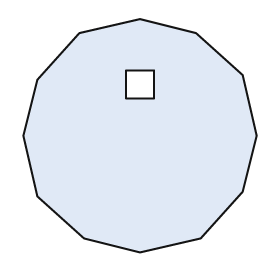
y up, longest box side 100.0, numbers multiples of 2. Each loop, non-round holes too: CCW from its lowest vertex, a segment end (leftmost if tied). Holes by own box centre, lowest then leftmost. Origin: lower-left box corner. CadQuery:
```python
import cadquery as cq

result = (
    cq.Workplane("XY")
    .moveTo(50.0, 0.0)
    .lineTo(76.0, 6.0)
    .lineTo(94.0, 26.0)
    .lineTo(100.0, 50.0)
    .lineTo(94.0, 76.0)
    .lineTo(74.0, 94.0)
    .lineTo(50.0, 100.0)
    .lineTo(24.0, 94.0)
    .lineTo(6.0, 74.0)
    .lineTo(0.0, 50.0)
    .lineTo(6.0, 24.0)
    .lineTo(26.0, 6.0)
    .close()
    .moveTo(44.0, 66.0)
    .lineTo(56.0, 66.0)
    .lineTo(56.0, 78.0)
    .lineTo(44.0, 78.0)
    .close()
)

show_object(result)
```